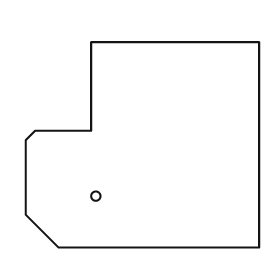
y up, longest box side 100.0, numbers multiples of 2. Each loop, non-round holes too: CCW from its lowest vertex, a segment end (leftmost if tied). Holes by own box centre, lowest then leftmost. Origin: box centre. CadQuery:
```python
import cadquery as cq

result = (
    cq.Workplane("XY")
    .moveTo(-36.0, -44.0)
    .lineTo(50.0, -44.0)
    .lineTo(50.0, 44.0)
    .lineTo(-22.0, 44.0)
    .lineTo(-22.0, 6.0)
    .lineTo(-46.0, 6.0)
    .lineTo(-50.0, 2.0)
    .lineTo(-50.0, -30.0)
    .close()
    .moveTo(-20.0, -22.0)
    .circle(2.0)
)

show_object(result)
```